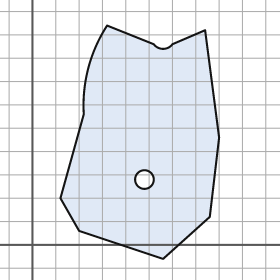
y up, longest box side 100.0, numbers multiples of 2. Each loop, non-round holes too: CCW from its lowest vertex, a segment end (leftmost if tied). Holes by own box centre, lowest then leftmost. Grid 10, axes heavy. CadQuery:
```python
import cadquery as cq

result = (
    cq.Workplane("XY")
    .moveTo(56.0, -6.0)
    .lineTo(76.0, 12.0)
    .lineTo(80.0, 46.0)
    .lineTo(74.0, 92.0)
    .lineTo(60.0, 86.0)
    .threePointArc((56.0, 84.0), (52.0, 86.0))
    .lineTo(32.0, 94.0)
    .threePointArc((24.0, 76.0), (22.0, 56.0))
    .lineTo(12.0, 20.0)
    .lineTo(20.0, 6.0)
    .close()
    .moveTo(48.0, 28.0)
    .circle(4.0)
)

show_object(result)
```